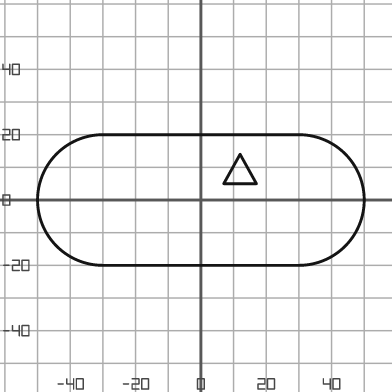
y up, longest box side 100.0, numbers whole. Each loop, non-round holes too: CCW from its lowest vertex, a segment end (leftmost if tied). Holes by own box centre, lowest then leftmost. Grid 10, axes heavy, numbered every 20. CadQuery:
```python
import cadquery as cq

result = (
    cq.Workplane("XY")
    .moveTo(-30.0, -20.0)
    .lineTo(30.0, -20.0)
    .threePointArc((50.0, 0.0), (30.0, 20.0))
    .lineTo(-30.0, 20.0)
    .threePointArc((-50.0, 0.0), (-30.0, -20.0))
    .close()
    .moveTo(7.0, 5.0)
    .lineTo(17.0, 5.0)
    .lineTo(12.0, 14.0)
    .close()
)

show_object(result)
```